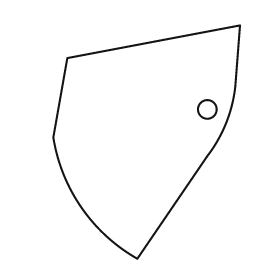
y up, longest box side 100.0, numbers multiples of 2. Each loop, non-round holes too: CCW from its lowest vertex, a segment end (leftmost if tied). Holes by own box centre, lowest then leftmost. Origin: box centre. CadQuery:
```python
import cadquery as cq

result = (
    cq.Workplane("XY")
    .moveTo(-4.0, -50.0)
    .lineTo(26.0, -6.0)
    .threePointArc((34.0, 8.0), (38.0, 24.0))
    .lineTo(40.0, 50.0)
    .lineTo(-34.0, 36.0)
    .lineTo(-40.0, 2.0)
    .threePointArc((-28.0, -28.0), (-4.0, -50.0))
    .close()
    .moveTo(26.0, 14.0)
    .circle(4.0)
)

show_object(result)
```